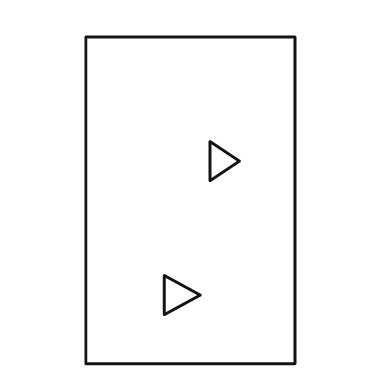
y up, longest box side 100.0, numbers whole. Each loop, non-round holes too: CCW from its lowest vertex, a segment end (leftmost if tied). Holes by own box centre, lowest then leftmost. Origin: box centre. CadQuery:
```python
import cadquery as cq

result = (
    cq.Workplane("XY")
    .moveTo(-32.0, -50.0)
    .lineTo(32.0, -50.0)
    .lineTo(32.0, 50.0)
    .lineTo(-32.0, 50.0)
    .close()
    .moveTo(-8.0, -35.0)
    .lineTo(3.0, -29.0)
    .lineTo(-8.0, -23.0)
    .close()
    .moveTo(6.0, 6.0)
    .lineTo(15.0, 12.0)
    .lineTo(6.0, 18.0)
    .close()
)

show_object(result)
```